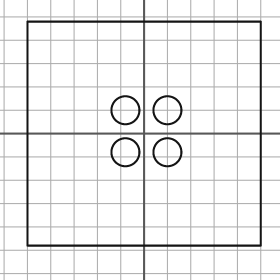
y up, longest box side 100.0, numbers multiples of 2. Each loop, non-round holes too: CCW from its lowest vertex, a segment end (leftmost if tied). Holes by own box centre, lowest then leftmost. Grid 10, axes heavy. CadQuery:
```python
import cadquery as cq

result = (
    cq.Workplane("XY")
    .moveTo(-50.0, -48.0)
    .lineTo(50.0, -48.0)
    .lineTo(50.0, 48.0)
    .lineTo(-50.0, 48.0)
    .close()
    .moveTo(-8.0, -8.0)
    .circle(6.0)
    .moveTo(10.0, -8.0)
    .circle(6.0)
    .moveTo(-8.0, 10.0)
    .circle(6.0)
    .moveTo(10.0, 10.0)
    .circle(6.0)
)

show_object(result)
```